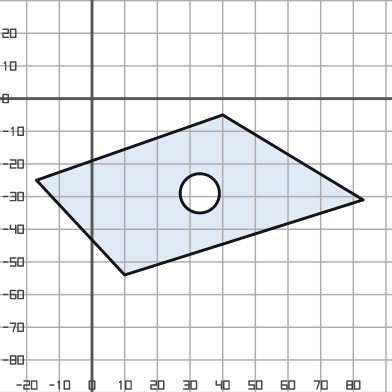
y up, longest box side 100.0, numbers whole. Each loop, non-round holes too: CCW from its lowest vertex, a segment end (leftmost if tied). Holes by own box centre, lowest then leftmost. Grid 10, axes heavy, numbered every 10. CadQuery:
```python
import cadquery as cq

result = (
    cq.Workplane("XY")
    .moveTo(10.0, -54.0)
    .lineTo(83.0, -31.0)
    .lineTo(40.0, -5.0)
    .lineTo(-17.0, -25.0)
    .close()
    .moveTo(33.0, -29.0)
    .circle(6.0)
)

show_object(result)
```